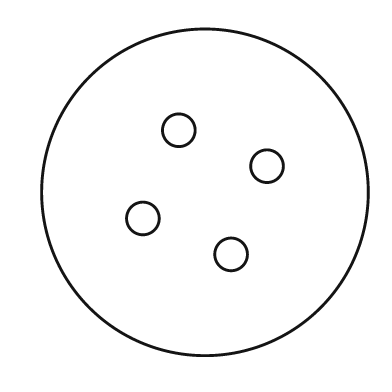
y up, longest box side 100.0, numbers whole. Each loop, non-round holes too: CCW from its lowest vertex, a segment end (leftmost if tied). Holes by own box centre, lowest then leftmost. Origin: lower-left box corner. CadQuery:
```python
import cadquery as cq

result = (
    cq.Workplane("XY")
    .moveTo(50.0, 50.0)
    .circle(50.0)
    .moveTo(58.0, 31.0)
    .circle(5.0)
    .moveTo(31.0, 42.0)
    .circle(5.0)
    .moveTo(69.0, 58.0)
    .circle(5.0)
    .moveTo(42.0, 69.0)
    .circle(5.0)
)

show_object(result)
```